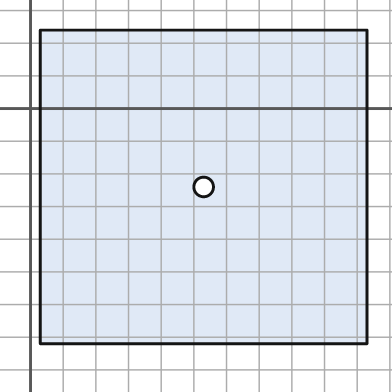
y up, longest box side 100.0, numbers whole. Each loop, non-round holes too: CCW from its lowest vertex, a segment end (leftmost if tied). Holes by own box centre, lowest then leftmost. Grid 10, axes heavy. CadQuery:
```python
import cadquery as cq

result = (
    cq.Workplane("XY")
    .moveTo(3.0, -72.0)
    .lineTo(103.0, -72.0)
    .lineTo(103.0, 24.0)
    .lineTo(3.0, 24.0)
    .close()
    .moveTo(53.0, -24.0)
    .circle(3.0)
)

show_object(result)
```